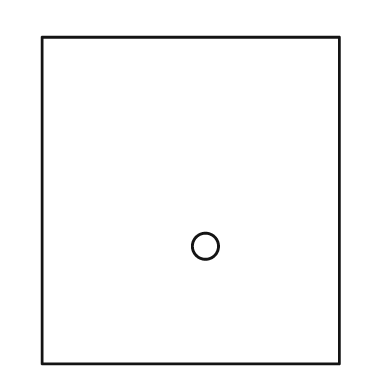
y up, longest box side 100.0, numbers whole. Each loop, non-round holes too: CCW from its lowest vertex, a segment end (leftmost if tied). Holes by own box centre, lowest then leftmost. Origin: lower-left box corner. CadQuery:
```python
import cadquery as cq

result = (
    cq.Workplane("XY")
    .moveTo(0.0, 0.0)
    .lineTo(91.0, 0.0)
    .lineTo(91.0, 100.0)
    .lineTo(0.0, 100.0)
    .close()
    .moveTo(50.0, 36.0)
    .circle(4.0)
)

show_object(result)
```